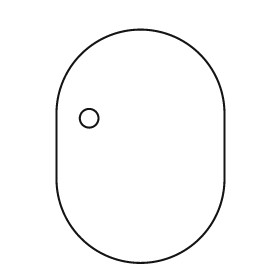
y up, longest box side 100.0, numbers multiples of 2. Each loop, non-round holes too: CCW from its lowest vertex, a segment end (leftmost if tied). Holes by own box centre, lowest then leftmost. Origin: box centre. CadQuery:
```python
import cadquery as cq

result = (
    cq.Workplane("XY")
    .moveTo(-36.0, -14.0)
    .threePointArc((0.0, -50.0), (36.0, -14.0))
    .lineTo(36.0, 14.0)
    .threePointArc((0.0, 50.0), (-36.0, 14.0))
    .close()
    .moveTo(-22.0, 12.0)
    .circle(4.0)
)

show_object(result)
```